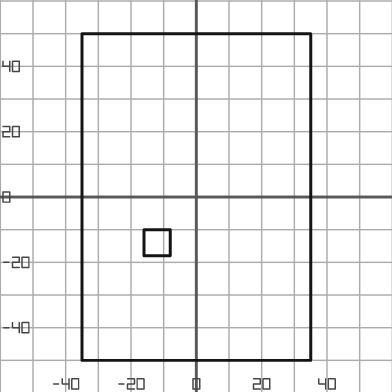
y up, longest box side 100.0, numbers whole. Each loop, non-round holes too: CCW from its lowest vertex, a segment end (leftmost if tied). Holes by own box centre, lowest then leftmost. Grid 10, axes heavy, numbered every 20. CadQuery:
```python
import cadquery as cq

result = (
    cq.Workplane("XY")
    .moveTo(-35.0, -50.0)
    .lineTo(35.0, -50.0)
    .lineTo(35.0, 50.0)
    .lineTo(-35.0, 50.0)
    .close()
    .moveTo(-16.0, -18.0)
    .lineTo(-8.0, -18.0)
    .lineTo(-8.0, -10.0)
    .lineTo(-16.0, -10.0)
    .close()
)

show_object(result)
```